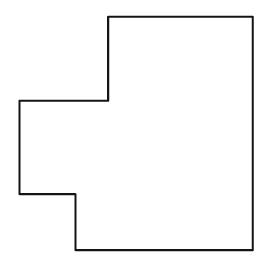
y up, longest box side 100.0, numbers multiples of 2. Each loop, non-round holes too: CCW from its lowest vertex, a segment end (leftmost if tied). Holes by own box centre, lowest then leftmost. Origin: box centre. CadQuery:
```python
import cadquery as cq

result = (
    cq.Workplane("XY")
    .moveTo(-26.0, -50.0)
    .lineTo(50.0, -50.0)
    .lineTo(50.0, 50.0)
    .lineTo(-12.0, 50.0)
    .lineTo(-12.0, 14.0)
    .lineTo(-50.0, 14.0)
    .lineTo(-50.0, -26.0)
    .lineTo(-26.0, -26.0)
    .close()
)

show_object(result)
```